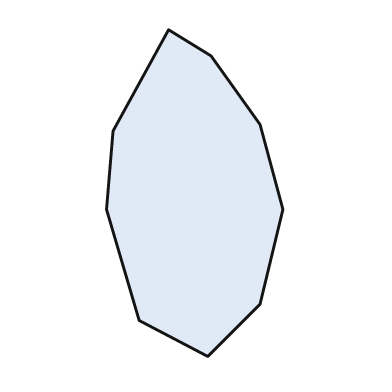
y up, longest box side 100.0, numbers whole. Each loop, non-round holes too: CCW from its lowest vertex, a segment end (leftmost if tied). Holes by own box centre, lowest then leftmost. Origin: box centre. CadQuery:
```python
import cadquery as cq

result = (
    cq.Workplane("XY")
    .moveTo(4.0, -50.0)
    .lineTo(20.0, -34.0)
    .lineTo(27.0, -5.0)
    .lineTo(20.0, 21.0)
    .lineTo(5.0, 42.0)
    .lineTo(-8.0, 50.0)
    .lineTo(-25.0, 19.0)
    .lineTo(-27.0, -5.0)
    .lineTo(-17.0, -39.0)
    .close()
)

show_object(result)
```